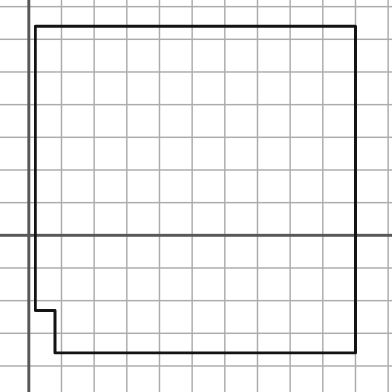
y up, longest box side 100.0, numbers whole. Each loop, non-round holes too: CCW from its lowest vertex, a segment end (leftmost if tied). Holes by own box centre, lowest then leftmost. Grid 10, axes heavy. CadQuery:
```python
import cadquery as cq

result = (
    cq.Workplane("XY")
    .moveTo(8.0, -36.0)
    .lineTo(100.0, -36.0)
    .lineTo(100.0, 64.0)
    .lineTo(2.0, 64.0)
    .lineTo(2.0, -23.0)
    .lineTo(8.0, -23.0)
    .close()
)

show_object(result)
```